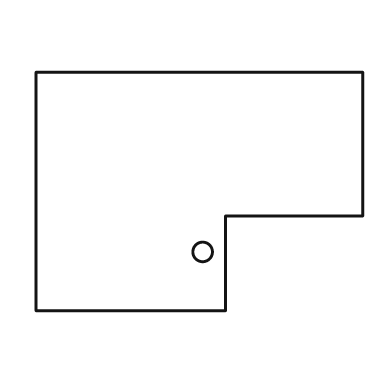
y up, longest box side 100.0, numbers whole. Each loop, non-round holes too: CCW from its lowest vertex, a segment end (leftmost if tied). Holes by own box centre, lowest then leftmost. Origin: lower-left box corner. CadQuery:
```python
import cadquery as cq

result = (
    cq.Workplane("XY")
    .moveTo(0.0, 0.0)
    .lineTo(58.0, 0.0)
    .lineTo(58.0, 29.0)
    .lineTo(100.0, 29.0)
    .lineTo(100.0, 73.0)
    .lineTo(0.0, 73.0)
    .close()
    .moveTo(51.0, 18.0)
    .circle(3.0)
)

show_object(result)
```